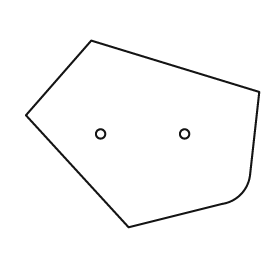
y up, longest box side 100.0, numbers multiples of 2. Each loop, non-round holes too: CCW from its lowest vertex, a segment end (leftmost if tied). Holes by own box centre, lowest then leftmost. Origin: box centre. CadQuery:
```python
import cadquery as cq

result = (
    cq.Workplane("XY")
    .moveTo(-6.0, -40.0)
    .lineTo(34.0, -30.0)
    .threePointArc((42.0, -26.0), (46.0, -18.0))
    .lineTo(50.0, 18.0)
    .lineTo(-22.0, 40.0)
    .lineTo(-50.0, 8.0)
    .close()
    .moveTo(-18.0, 0.0)
    .circle(2.0)
    .moveTo(18.0, 0.0)
    .circle(2.0)
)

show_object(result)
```